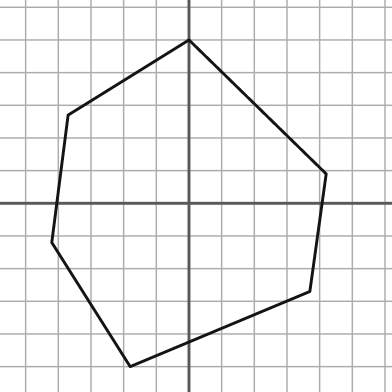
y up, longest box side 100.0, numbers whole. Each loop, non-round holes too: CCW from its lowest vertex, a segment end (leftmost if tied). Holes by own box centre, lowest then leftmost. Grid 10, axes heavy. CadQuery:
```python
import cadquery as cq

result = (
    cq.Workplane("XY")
    .moveTo(-18.0, -50.0)
    .lineTo(37.0, -27.0)
    .lineTo(42.0, 9.0)
    .lineTo(0.0, 50.0)
    .lineTo(-37.0, 27.0)
    .lineTo(-42.0, -12.0)
    .close()
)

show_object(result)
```